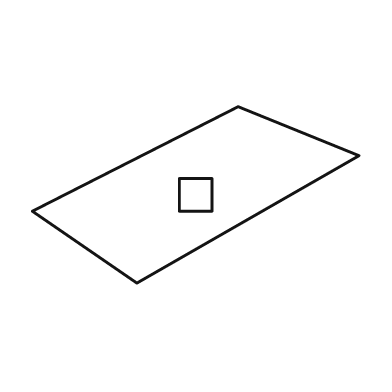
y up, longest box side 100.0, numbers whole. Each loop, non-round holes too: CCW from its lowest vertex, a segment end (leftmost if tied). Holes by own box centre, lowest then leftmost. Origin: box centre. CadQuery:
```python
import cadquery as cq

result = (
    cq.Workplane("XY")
    .moveTo(-18.0, -27.0)
    .lineTo(50.0, 12.0)
    .lineTo(13.0, 27.0)
    .lineTo(-50.0, -5.0)
    .close()
    .moveTo(-5.0, -5.0)
    .lineTo(5.0, -5.0)
    .lineTo(5.0, 5.0)
    .lineTo(-5.0, 5.0)
    .close()
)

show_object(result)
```